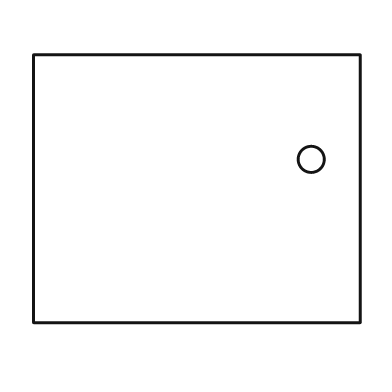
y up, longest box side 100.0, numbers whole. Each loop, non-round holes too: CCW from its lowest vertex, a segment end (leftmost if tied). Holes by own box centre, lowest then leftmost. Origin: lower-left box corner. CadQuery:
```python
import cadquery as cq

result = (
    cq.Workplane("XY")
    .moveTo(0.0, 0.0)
    .lineTo(100.0, 0.0)
    .lineTo(100.0, 82.0)
    .lineTo(0.0, 82.0)
    .close()
    .moveTo(85.0, 50.0)
    .circle(4.0)
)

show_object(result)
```